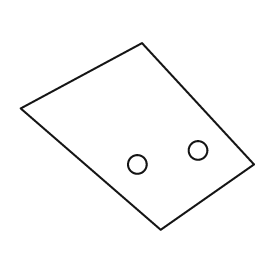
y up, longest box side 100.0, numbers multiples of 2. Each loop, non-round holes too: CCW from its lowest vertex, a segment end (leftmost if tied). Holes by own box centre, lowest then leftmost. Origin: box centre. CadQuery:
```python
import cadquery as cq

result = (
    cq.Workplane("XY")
    .moveTo(10.0, -40.0)
    .lineTo(50.0, -12.0)
    .lineTo(2.0, 40.0)
    .lineTo(-50.0, 12.0)
    .close()
    .moveTo(0.0, -12.0)
    .circle(4.0)
    .moveTo(26.0, -6.0)
    .circle(4.0)
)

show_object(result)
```